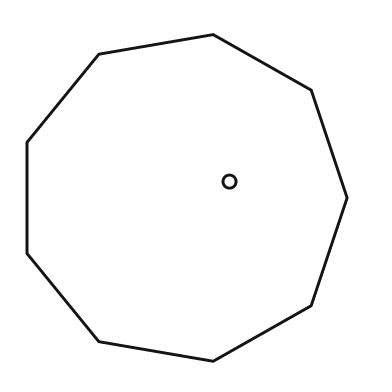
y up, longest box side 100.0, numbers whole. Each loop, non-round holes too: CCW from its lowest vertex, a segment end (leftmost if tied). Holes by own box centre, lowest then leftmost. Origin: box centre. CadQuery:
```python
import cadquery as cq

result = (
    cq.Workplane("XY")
    .moveTo(8.0, -50.0)
    .lineTo(38.0, -33.0)
    .lineTo(49.0, 0.0)
    .lineTo(38.0, 33.0)
    .lineTo(8.0, 50.0)
    .lineTo(-27.0, 44.0)
    .lineTo(-49.0, 17.0)
    .lineTo(-49.0, -17.0)
    .lineTo(-27.0, -44.0)
    .close()
    .moveTo(13.0, 5.0)
    .circle(2.0)
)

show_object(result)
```